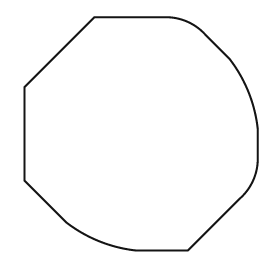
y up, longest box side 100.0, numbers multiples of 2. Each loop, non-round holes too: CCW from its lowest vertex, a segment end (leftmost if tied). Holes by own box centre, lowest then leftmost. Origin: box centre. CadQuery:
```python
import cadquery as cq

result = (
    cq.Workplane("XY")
    .moveTo(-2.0, -50.0)
    .lineTo(20.0, -50.0)
    .lineTo(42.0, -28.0)
    .threePointArc((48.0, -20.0), (50.0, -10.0))
    .lineTo(50.0, 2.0)
    .threePointArc((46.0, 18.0), (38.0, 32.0))
    .lineTo(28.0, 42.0)
    .threePointArc((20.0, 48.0), (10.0, 50.0))
    .lineTo(-20.0, 50.0)
    .lineTo(-50.0, 20.0)
    .lineTo(-50.0, -20.0)
    .lineTo(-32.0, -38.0)
    .threePointArc((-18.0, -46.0), (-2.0, -50.0))
    .close()
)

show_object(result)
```